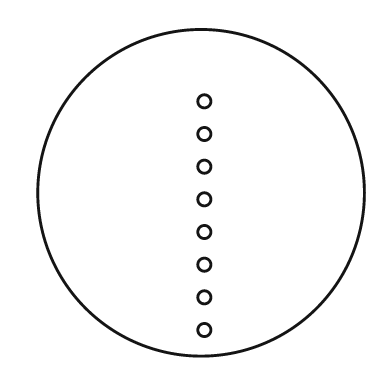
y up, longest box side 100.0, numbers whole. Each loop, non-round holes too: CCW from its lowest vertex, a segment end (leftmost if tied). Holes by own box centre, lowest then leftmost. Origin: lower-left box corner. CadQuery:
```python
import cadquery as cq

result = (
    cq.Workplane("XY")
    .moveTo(50.0, 50.0)
    .circle(50.0)
    .moveTo(51.0, 8.0)
    .circle(2.0)
    .moveTo(51.0, 18.0)
    .circle(2.0)
    .moveTo(51.0, 28.0)
    .circle(2.0)
    .moveTo(51.0, 38.0)
    .circle(2.0)
    .moveTo(51.0, 48.0)
    .circle(2.0)
    .moveTo(51.0, 58.0)
    .circle(2.0)
    .moveTo(51.0, 68.0)
    .circle(2.0)
    .moveTo(51.0, 78.0)
    .circle(2.0)
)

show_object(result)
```